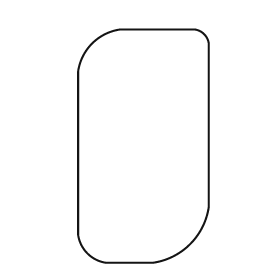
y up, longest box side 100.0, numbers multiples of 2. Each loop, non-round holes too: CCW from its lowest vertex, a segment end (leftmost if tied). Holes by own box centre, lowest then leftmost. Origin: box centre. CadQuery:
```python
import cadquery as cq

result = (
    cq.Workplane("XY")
    .moveTo(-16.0, -50.0)
    .lineTo(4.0, -50.0)
    .threePointArc((20.0, -42.0), (28.0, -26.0))
    .lineTo(28.0, 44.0)
    .threePointArc((26.0, 48.0), (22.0, 50.0))
    .lineTo(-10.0, 50.0)
    .threePointArc((-22.0, 44.0), (-28.0, 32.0))
    .lineTo(-28.0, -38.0)
    .threePointArc((-24.0, -46.0), (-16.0, -50.0))
    .close()
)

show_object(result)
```